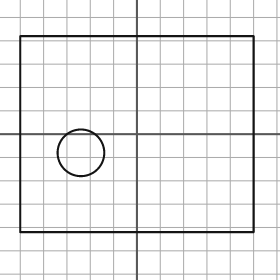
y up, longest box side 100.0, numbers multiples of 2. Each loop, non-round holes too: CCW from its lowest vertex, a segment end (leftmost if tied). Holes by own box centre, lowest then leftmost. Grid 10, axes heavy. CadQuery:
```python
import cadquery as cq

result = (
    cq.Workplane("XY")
    .moveTo(-50.0, -42.0)
    .lineTo(50.0, -42.0)
    .lineTo(50.0, 42.0)
    .lineTo(-50.0, 42.0)
    .close()
    .moveTo(-24.0, -8.0)
    .circle(10.0)
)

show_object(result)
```